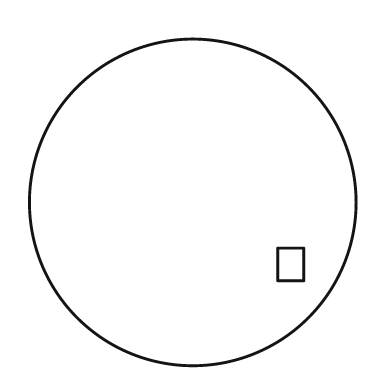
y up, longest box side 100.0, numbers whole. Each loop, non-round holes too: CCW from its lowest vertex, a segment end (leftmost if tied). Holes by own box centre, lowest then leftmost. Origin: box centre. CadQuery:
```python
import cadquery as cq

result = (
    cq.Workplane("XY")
    .moveTo(0.0, 0.0)
    .circle(50.0)
    .moveTo(26.0, -24.0)
    .lineTo(34.0, -24.0)
    .lineTo(34.0, -14.0)
    .lineTo(26.0, -14.0)
    .close()
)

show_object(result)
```